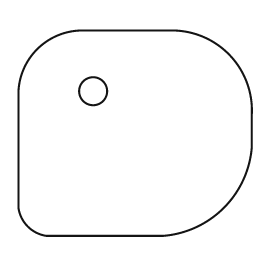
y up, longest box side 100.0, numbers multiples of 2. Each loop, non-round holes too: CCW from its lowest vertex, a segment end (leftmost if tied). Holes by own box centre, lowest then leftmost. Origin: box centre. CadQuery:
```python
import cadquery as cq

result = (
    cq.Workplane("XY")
    .moveTo(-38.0, -44.0)
    .lineTo(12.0, -44.0)
    .threePointArc((38.0, -32.0), (50.0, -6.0))
    .lineTo(50.0, 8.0)
    .threePointArc((40.0, 34.0), (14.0, 44.0))
    .lineTo(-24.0, 44.0)
    .threePointArc((-42.0, 36.0), (-50.0, 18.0))
    .lineTo(-50.0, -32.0)
    .threePointArc((-46.0, -40.0), (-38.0, -44.0))
    .close()
    .moveTo(-18.0, 18.0)
    .circle(6.0)
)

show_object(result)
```